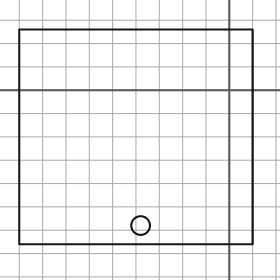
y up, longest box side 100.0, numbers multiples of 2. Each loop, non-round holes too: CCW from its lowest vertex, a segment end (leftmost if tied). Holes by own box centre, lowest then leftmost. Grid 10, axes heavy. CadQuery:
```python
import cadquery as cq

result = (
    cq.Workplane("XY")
    .moveTo(-90.0, -66.0)
    .lineTo(10.0, -66.0)
    .lineTo(10.0, 26.0)
    .lineTo(-90.0, 26.0)
    .close()
    .moveTo(-38.0, -58.0)
    .circle(4.0)
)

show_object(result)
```